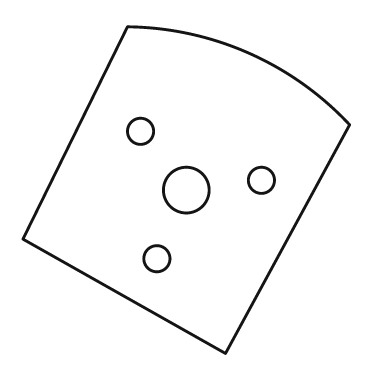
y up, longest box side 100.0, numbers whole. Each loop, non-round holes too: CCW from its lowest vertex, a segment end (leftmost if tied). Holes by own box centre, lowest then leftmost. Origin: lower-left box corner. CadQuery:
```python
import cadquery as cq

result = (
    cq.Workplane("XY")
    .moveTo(62.0, 0.0)
    .lineTo(100.0, 70.0)
    .threePointArc((69.0, 92.0), (32.0, 100.0))
    .lineTo(0.0, 35.0)
    .close()
    .moveTo(41.0, 29.0)
    .circle(4.0)
    .moveTo(50.0, 50.0)
    .circle(7.0)
    .moveTo(73.0, 53.0)
    .circle(4.0)
    .moveTo(36.0, 68.0)
    .circle(4.0)
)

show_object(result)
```